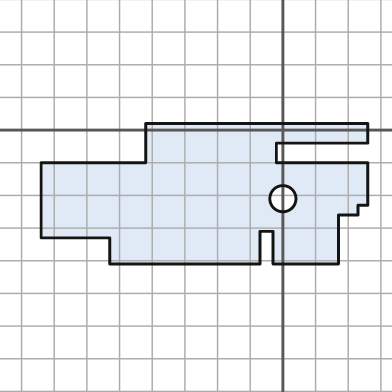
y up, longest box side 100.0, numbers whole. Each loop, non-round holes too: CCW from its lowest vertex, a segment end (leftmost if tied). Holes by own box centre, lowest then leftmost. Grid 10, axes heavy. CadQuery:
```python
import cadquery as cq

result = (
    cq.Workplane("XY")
    .moveTo(-53.0, -41.0)
    .lineTo(-7.0, -41.0)
    .lineTo(-7.0, -31.0)
    .lineTo(-3.0, -31.0)
    .lineTo(-3.0, -41.0)
    .lineTo(17.0, -41.0)
    .lineTo(17.0, -26.0)
    .lineTo(23.0, -26.0)
    .lineTo(23.0, -23.0)
    .lineTo(26.0, -23.0)
    .lineTo(26.0, -10.0)
    .lineTo(-2.0, -10.0)
    .lineTo(-2.0, -4.0)
    .lineTo(26.0, -4.0)
    .lineTo(26.0, 2.0)
    .lineTo(-42.0, 2.0)
    .lineTo(-42.0, -10.0)
    .lineTo(-74.0, -10.0)
    .lineTo(-74.0, -33.0)
    .lineTo(-53.0, -33.0)
    .close()
    .moveTo(0.0, -21.0)
    .circle(4.0)
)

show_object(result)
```